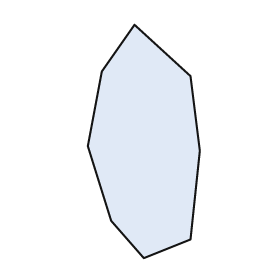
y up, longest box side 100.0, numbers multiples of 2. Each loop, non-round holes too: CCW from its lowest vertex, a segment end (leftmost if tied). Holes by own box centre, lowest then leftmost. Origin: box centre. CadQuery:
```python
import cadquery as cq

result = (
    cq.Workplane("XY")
    .moveTo(0.0, -50.0)
    .lineTo(20.0, -42.0)
    .lineTo(24.0, -4.0)
    .lineTo(20.0, 28.0)
    .lineTo(-4.0, 50.0)
    .lineTo(-18.0, 30.0)
    .lineTo(-24.0, -2.0)
    .lineTo(-14.0, -34.0)
    .close()
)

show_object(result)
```